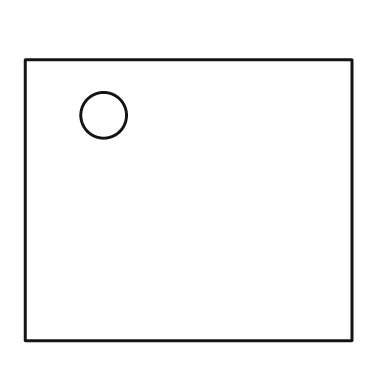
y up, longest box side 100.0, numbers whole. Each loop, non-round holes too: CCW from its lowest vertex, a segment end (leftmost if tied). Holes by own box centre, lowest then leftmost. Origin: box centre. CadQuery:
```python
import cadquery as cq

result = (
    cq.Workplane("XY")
    .moveTo(-50.0, -43.0)
    .lineTo(50.0, -43.0)
    .lineTo(50.0, 43.0)
    .lineTo(-50.0, 43.0)
    .close()
    .moveTo(-26.0, 26.0)
    .circle(7.0)
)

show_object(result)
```